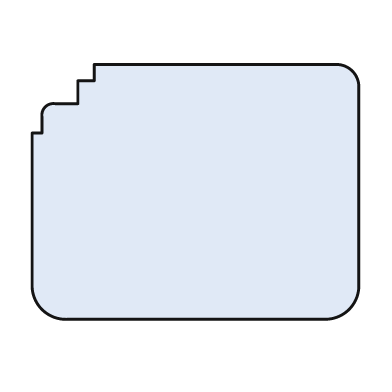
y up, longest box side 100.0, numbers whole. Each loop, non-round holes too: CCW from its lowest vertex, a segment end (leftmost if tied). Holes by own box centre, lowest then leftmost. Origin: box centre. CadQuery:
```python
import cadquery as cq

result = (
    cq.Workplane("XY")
    .moveTo(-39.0, -39.0)
    .lineTo(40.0, -39.0)
    .threePointArc((47.0, -36.0), (50.0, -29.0))
    .lineTo(50.0, 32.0)
    .threePointArc((48.0, 37.0), (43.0, 39.0))
    .lineTo(-31.0, 39.0)
    .lineTo(-31.0, 34.0)
    .lineTo(-36.0, 34.0)
    .lineTo(-36.0, 27.0)
    .lineTo(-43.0, 27.0)
    .threePointArc((-46.0, 26.0), (-47.0, 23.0))
    .lineTo(-47.0, 18.0)
    .lineTo(-50.0, 18.0)
    .lineTo(-50.0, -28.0)
    .threePointArc((-47.0, -36.0), (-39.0, -39.0))
    .close()
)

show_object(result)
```